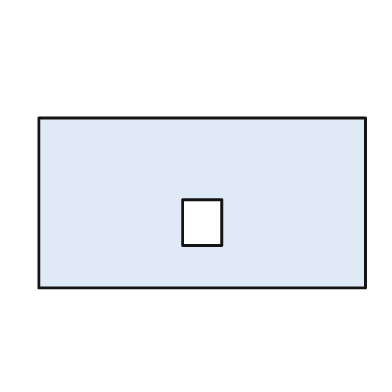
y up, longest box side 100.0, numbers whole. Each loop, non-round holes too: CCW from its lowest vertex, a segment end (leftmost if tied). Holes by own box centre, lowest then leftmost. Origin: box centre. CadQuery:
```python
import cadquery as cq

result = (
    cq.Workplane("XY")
    .moveTo(-50.0, -26.0)
    .lineTo(50.0, -26.0)
    .lineTo(50.0, 26.0)
    .lineTo(-50.0, 26.0)
    .close()
    .moveTo(-6.0, -13.0)
    .lineTo(6.0, -13.0)
    .lineTo(6.0, 1.0)
    .lineTo(-6.0, 1.0)
    .close()
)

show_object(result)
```